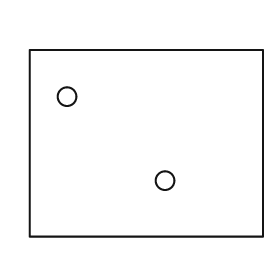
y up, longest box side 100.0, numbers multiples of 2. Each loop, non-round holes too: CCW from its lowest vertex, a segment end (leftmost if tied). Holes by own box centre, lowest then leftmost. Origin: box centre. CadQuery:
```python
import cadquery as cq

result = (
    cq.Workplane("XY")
    .moveTo(-50.0, -40.0)
    .lineTo(50.0, -40.0)
    .lineTo(50.0, 40.0)
    .lineTo(-50.0, 40.0)
    .close()
    .moveTo(8.0, -16.0)
    .circle(4.0)
    .moveTo(-34.0, 20.0)
    .circle(4.0)
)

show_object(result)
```